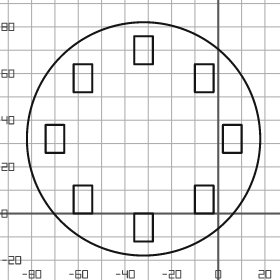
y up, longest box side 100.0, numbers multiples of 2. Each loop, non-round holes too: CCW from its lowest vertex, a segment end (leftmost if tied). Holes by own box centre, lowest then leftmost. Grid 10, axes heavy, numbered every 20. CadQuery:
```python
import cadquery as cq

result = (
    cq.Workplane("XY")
    .moveTo(-32.0, 32.0)
    .circle(50.0)
    .moveTo(-36.0, -12.0)
    .lineTo(-28.0, -12.0)
    .lineTo(-28.0, 0.0)
    .lineTo(-36.0, 0.0)
    .close()
    .moveTo(-62.0, 0.0)
    .lineTo(-54.0, 0.0)
    .lineTo(-54.0, 12.0)
    .lineTo(-62.0, 12.0)
    .close()
    .moveTo(-10.0, 0.0)
    .lineTo(-2.0, 0.0)
    .lineTo(-2.0, 12.0)
    .lineTo(-10.0, 12.0)
    .close()
    .moveTo(-74.0, 26.0)
    .lineTo(-66.0, 26.0)
    .lineTo(-66.0, 38.0)
    .lineTo(-74.0, 38.0)
    .close()
    .moveTo(2.0, 26.0)
    .lineTo(10.0, 26.0)
    .lineTo(10.0, 38.0)
    .lineTo(2.0, 38.0)
    .close()
    .moveTo(-62.0, 52.0)
    .lineTo(-54.0, 52.0)
    .lineTo(-54.0, 64.0)
    .lineTo(-62.0, 64.0)
    .close()
    .moveTo(-10.0, 52.0)
    .lineTo(-2.0, 52.0)
    .lineTo(-2.0, 64.0)
    .lineTo(-10.0, 64.0)
    .close()
    .moveTo(-36.0, 64.0)
    .lineTo(-28.0, 64.0)
    .lineTo(-28.0, 76.0)
    .lineTo(-36.0, 76.0)
    .close()
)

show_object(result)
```